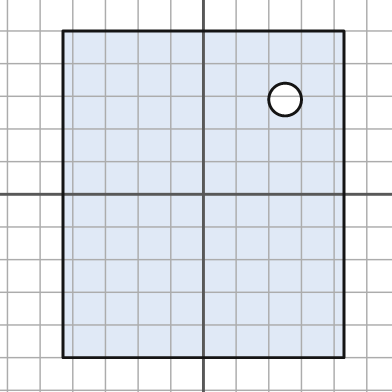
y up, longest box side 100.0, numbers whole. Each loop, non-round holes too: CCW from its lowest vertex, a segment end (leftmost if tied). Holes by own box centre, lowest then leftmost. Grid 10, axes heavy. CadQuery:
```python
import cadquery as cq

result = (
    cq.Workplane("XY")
    .moveTo(-43.0, -50.0)
    .lineTo(43.0, -50.0)
    .lineTo(43.0, 50.0)
    .lineTo(-43.0, 50.0)
    .close()
    .moveTo(25.0, 29.0)
    .circle(5.0)
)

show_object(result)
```